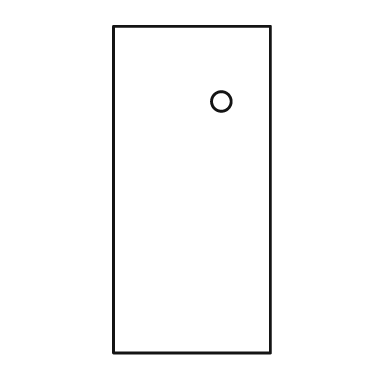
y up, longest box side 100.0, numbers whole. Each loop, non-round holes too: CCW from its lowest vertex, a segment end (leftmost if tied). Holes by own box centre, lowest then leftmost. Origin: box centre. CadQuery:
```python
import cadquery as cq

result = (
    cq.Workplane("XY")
    .moveTo(-24.0, -50.0)
    .lineTo(24.0, -50.0)
    .lineTo(24.0, 50.0)
    .lineTo(-24.0, 50.0)
    .close()
    .moveTo(9.0, 27.0)
    .circle(3.0)
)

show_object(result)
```